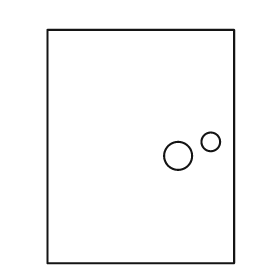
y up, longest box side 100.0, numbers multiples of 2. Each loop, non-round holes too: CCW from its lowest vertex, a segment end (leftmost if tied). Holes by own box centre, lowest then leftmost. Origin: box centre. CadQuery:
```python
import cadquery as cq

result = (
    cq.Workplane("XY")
    .moveTo(-40.0, -50.0)
    .lineTo(40.0, -50.0)
    .lineTo(40.0, 50.0)
    .lineTo(-40.0, 50.0)
    .close()
    .moveTo(16.0, -4.0)
    .circle(6.0)
    .moveTo(30.0, 2.0)
    .circle(4.0)
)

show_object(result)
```